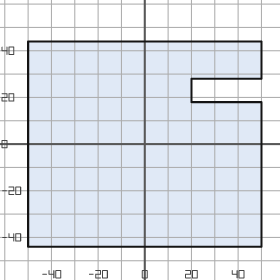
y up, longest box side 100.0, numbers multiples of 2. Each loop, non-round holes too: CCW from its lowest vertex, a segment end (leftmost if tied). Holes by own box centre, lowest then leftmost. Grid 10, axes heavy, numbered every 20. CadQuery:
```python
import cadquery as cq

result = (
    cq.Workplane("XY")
    .moveTo(-50.0, -44.0)
    .lineTo(50.0, -44.0)
    .lineTo(50.0, 18.0)
    .lineTo(20.0, 18.0)
    .lineTo(20.0, 28.0)
    .lineTo(50.0, 28.0)
    .lineTo(50.0, 44.0)
    .lineTo(-50.0, 44.0)
    .close()
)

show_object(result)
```